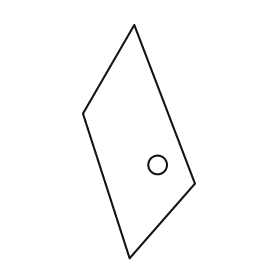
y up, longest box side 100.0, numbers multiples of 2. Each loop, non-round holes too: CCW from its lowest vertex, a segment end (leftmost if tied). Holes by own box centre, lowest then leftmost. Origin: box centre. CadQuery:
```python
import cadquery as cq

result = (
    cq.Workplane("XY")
    .moveTo(-4.0, -50.0)
    .lineTo(24.0, -18.0)
    .lineTo(-2.0, 50.0)
    .lineTo(-24.0, 12.0)
    .close()
    .moveTo(8.0, -10.0)
    .circle(4.0)
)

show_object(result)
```